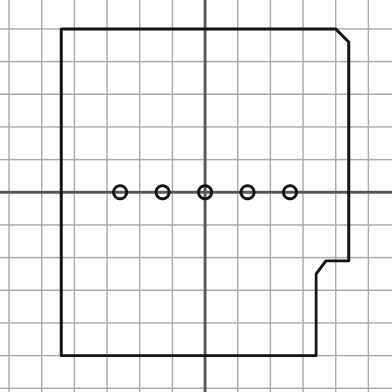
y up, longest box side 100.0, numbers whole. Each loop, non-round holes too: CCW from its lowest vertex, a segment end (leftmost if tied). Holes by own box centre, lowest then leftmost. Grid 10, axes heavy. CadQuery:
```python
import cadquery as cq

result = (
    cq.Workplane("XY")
    .moveTo(-44.0, -50.0)
    .lineTo(34.0, -50.0)
    .lineTo(34.0, -25.0)
    .lineTo(37.0, -21.0)
    .lineTo(44.0, -21.0)
    .lineTo(44.0, 46.0)
    .lineTo(40.0, 50.0)
    .lineTo(-44.0, 50.0)
    .close()
    .moveTo(-26.0, 0.0)
    .circle(2.0)
    .moveTo(-13.0, 0.0)
    .circle(2.0)
    .moveTo(0.0, 0.0)
    .circle(2.0)
    .moveTo(13.0, 0.0)
    .circle(2.0)
    .moveTo(26.0, 0.0)
    .circle(2.0)
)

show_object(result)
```